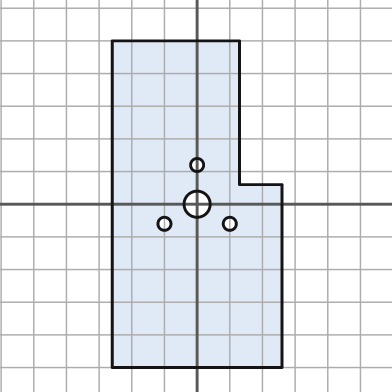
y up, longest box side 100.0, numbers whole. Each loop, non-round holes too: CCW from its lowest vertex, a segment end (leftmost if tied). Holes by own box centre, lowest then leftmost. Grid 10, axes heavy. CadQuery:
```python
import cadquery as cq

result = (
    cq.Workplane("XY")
    .moveTo(-26.0, -50.0)
    .lineTo(26.0, -50.0)
    .lineTo(26.0, 6.0)
    .lineTo(13.0, 6.0)
    .lineTo(13.0, 50.0)
    .lineTo(-26.0, 50.0)
    .close()
    .moveTo(-10.0, -6.0)
    .circle(2.0)
    .moveTo(10.0, -6.0)
    .circle(2.0)
    .moveTo(0.0, 0.0)
    .circle(4.0)
    .moveTo(0.0, 12.0)
    .circle(2.0)
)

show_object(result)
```